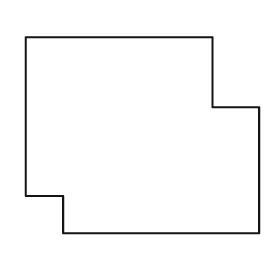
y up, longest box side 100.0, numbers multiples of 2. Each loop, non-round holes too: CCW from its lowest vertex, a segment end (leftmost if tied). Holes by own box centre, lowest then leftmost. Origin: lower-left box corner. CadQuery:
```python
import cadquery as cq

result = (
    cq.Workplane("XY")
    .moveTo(16.0, 0.0)
    .lineTo(100.0, 0.0)
    .lineTo(100.0, 54.0)
    .lineTo(80.0, 54.0)
    .lineTo(80.0, 84.0)
    .lineTo(0.0, 84.0)
    .lineTo(0.0, 16.0)
    .lineTo(16.0, 16.0)
    .close()
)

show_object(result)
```